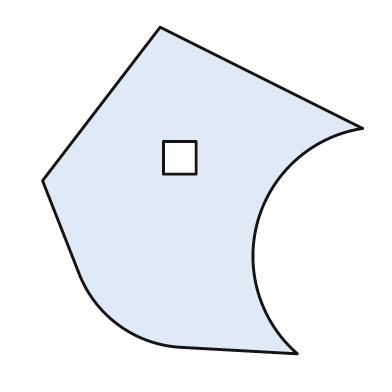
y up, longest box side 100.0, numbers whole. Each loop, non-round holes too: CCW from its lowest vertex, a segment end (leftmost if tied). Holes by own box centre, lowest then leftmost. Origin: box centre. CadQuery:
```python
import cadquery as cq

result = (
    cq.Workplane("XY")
    .moveTo(29.0, -50.0)
    .threePointArc((17.0, -9.0), (49.0, 19.0))
    .lineTo(-13.0, 50.0)
    .lineTo(-49.0, 3.0)
    .lineTo(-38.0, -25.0)
    .threePointArc((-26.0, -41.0), (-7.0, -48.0))
    .close()
    .moveTo(-12.0, 5.0)
    .lineTo(-2.0, 5.0)
    .lineTo(-2.0, 15.0)
    .lineTo(-12.0, 15.0)
    .close()
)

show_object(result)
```